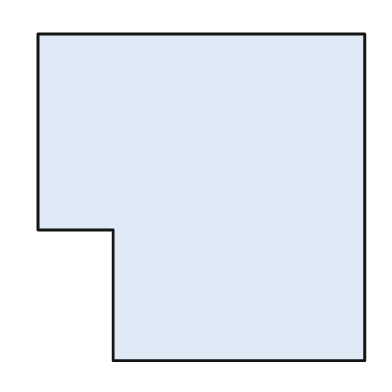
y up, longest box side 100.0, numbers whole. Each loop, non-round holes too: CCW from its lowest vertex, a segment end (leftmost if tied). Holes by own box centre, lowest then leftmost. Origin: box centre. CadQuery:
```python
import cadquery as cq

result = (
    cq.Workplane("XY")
    .moveTo(-27.0, -50.0)
    .lineTo(50.0, -50.0)
    .lineTo(50.0, 50.0)
    .lineTo(-50.0, 50.0)
    .lineTo(-50.0, -10.0)
    .lineTo(-27.0, -10.0)
    .close()
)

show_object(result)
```